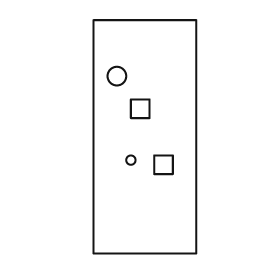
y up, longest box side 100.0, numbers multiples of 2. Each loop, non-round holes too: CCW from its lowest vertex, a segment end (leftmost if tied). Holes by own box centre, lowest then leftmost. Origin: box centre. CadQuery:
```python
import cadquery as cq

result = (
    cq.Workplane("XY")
    .moveTo(-22.0, -50.0)
    .lineTo(22.0, -50.0)
    .lineTo(22.0, 50.0)
    .lineTo(-22.0, 50.0)
    .close()
    .moveTo(4.0, -16.0)
    .lineTo(12.0, -16.0)
    .lineTo(12.0, -8.0)
    .lineTo(4.0, -8.0)
    .close()
    .moveTo(-6.0, -10.0)
    .circle(2.0)
    .moveTo(-6.0, 8.0)
    .lineTo(2.0, 8.0)
    .lineTo(2.0, 16.0)
    .lineTo(-6.0, 16.0)
    .close()
    .moveTo(-12.0, 26.0)
    .circle(4.0)
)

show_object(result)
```